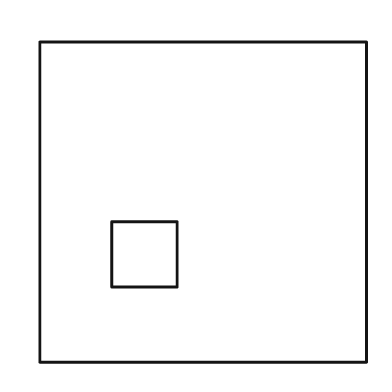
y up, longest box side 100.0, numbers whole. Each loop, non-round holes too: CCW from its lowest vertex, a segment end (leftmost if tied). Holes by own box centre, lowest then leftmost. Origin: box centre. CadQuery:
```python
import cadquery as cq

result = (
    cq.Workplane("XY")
    .moveTo(-50.0, -49.0)
    .lineTo(50.0, -49.0)
    .lineTo(50.0, 49.0)
    .lineTo(-50.0, 49.0)
    .close()
    .moveTo(-28.0, -26.0)
    .lineTo(-8.0, -26.0)
    .lineTo(-8.0, -6.0)
    .lineTo(-28.0, -6.0)
    .close()
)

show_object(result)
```